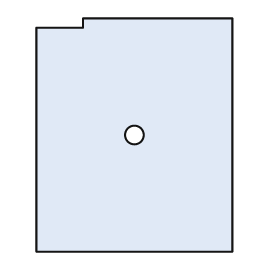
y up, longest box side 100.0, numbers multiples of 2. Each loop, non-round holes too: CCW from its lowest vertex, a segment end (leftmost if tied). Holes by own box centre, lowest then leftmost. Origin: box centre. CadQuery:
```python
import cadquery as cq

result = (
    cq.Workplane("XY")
    .moveTo(-42.0, -50.0)
    .lineTo(42.0, -50.0)
    .lineTo(42.0, 50.0)
    .lineTo(-22.0, 50.0)
    .lineTo(-22.0, 46.0)
    .lineTo(-42.0, 46.0)
    .close()
    .moveTo(0.0, 0.0)
    .circle(4.0)
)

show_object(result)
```